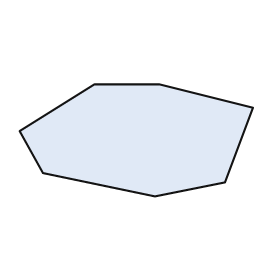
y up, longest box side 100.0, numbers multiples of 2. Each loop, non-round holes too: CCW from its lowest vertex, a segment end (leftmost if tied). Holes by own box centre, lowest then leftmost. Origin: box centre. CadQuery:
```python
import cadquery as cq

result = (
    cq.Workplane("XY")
    .moveTo(8.0, -24.0)
    .lineTo(38.0, -18.0)
    .lineTo(50.0, 14.0)
    .lineTo(10.0, 24.0)
    .lineTo(-18.0, 24.0)
    .lineTo(-50.0, 4.0)
    .lineTo(-40.0, -14.0)
    .close()
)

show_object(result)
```